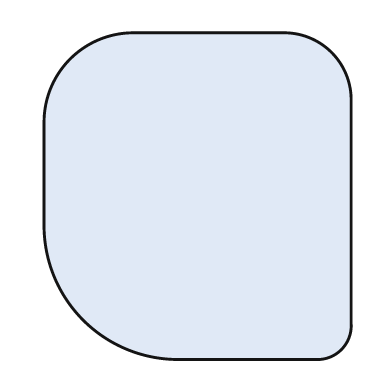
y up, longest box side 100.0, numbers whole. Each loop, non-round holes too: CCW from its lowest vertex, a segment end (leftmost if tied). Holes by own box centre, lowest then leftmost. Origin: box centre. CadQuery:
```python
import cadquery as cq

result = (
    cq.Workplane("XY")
    .moveTo(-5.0, -50.0)
    .lineTo(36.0, -50.0)
    .threePointArc((44.0, -47.0), (47.0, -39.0))
    .lineTo(47.0, 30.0)
    .threePointArc((41.0, 44.0), (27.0, 50.0))
    .lineTo(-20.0, 50.0)
    .threePointArc((-39.0, 42.0), (-47.0, 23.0))
    .lineTo(-47.0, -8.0)
    .threePointArc((-35.0, -38.0), (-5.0, -50.0))
    .close()
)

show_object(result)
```